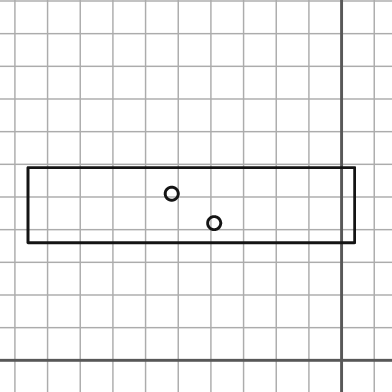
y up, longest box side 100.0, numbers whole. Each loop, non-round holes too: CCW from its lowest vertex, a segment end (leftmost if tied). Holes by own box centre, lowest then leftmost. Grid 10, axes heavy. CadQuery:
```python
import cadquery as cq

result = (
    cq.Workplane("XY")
    .moveTo(-96.0, 36.0)
    .lineTo(4.0, 36.0)
    .lineTo(4.0, 59.0)
    .lineTo(-96.0, 59.0)
    .close()
    .moveTo(-39.0, 42.0)
    .circle(2.0)
    .moveTo(-52.0, 51.0)
    .circle(2.0)
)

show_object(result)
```